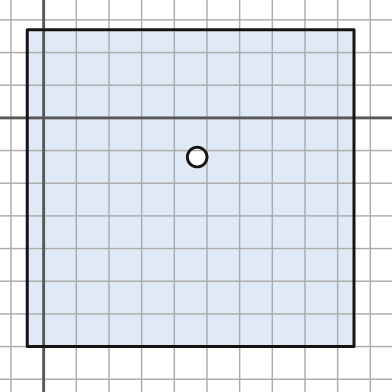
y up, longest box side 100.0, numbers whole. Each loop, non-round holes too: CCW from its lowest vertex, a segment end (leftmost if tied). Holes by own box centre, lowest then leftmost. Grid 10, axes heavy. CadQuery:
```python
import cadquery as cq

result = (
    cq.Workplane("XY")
    .moveTo(-5.0, -70.0)
    .lineTo(95.0, -70.0)
    .lineTo(95.0, 27.0)
    .lineTo(-5.0, 27.0)
    .close()
    .moveTo(47.0, -12.0)
    .circle(3.0)
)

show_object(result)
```